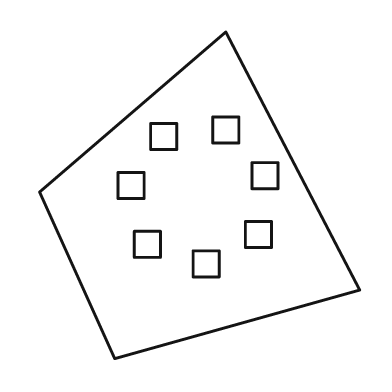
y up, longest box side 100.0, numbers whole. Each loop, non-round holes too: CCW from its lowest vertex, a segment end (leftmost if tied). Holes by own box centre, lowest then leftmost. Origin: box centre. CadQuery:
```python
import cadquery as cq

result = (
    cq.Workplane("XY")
    .moveTo(-26.0, -50.0)
    .lineTo(49.0, -29.0)
    .lineTo(8.0, 50.0)
    .lineTo(-49.0, 1.0)
    .close()
    .moveTo(-2.0, -25.0)
    .lineTo(6.0, -25.0)
    .lineTo(6.0, -17.0)
    .lineTo(-2.0, -17.0)
    .close()
    .moveTo(-20.0, -19.0)
    .lineTo(-12.0, -19.0)
    .lineTo(-12.0, -11.0)
    .lineTo(-20.0, -11.0)
    .close()
    .moveTo(14.0, -16.0)
    .lineTo(22.0, -16.0)
    .lineTo(22.0, -8.0)
    .lineTo(14.0, -8.0)
    .close()
    .moveTo(-25.0, -1.0)
    .lineTo(-17.0, -1.0)
    .lineTo(-17.0, 7.0)
    .lineTo(-25.0, 7.0)
    .close()
    .moveTo(16.0, 2.0)
    .lineTo(24.0, 2.0)
    .lineTo(24.0, 10.0)
    .lineTo(16.0, 10.0)
    .close()
    .moveTo(-15.0, 14.0)
    .lineTo(-7.0, 14.0)
    .lineTo(-7.0, 22.0)
    .lineTo(-15.0, 22.0)
    .close()
    .moveTo(4.0, 16.0)
    .lineTo(12.0, 16.0)
    .lineTo(12.0, 24.0)
    .lineTo(4.0, 24.0)
    .close()
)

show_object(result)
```